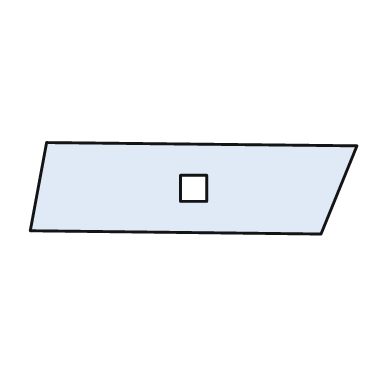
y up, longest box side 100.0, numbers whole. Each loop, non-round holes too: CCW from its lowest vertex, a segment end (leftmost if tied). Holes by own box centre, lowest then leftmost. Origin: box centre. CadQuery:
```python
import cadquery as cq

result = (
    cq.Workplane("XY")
    .moveTo(39.0, -14.0)
    .lineTo(50.0, 13.0)
    .lineTo(-45.0, 14.0)
    .lineTo(-50.0, -13.0)
    .close()
    .moveTo(-4.0, -4.0)
    .lineTo(4.0, -4.0)
    .lineTo(4.0, 4.0)
    .lineTo(-4.0, 4.0)
    .close()
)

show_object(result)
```